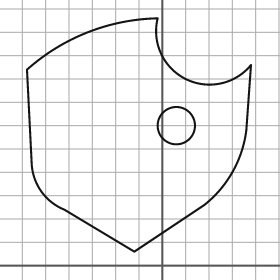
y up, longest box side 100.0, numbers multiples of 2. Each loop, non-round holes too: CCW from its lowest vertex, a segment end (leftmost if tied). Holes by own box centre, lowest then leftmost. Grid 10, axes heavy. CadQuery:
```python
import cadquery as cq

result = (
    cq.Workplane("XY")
    .moveTo(-12.0, 6.0)
    .lineTo(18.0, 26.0)
    .threePointArc((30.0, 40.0), (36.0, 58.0))
    .lineTo(38.0, 86.0)
    .threePointArc((10.0, 80.0), (-2.0, 106.0))
    .threePointArc((-32.0, 100.0), (-58.0, 84.0))
    .lineTo(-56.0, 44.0)
    .threePointArc((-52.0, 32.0), (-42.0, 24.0))
    .close()
    .moveTo(6.0, 60.0)
    .circle(8.0)
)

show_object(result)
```